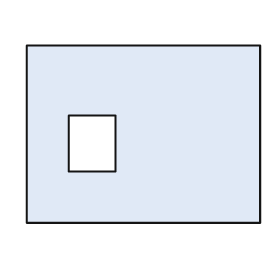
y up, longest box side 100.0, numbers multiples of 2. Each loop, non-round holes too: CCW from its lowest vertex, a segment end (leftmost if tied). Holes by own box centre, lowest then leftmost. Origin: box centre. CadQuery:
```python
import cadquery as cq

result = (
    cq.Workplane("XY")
    .moveTo(-50.0, -38.0)
    .lineTo(50.0, -38.0)
    .lineTo(50.0, 38.0)
    .lineTo(-50.0, 38.0)
    .close()
    .moveTo(-32.0, -16.0)
    .lineTo(-12.0, -16.0)
    .lineTo(-12.0, 8.0)
    .lineTo(-32.0, 8.0)
    .close()
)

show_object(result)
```